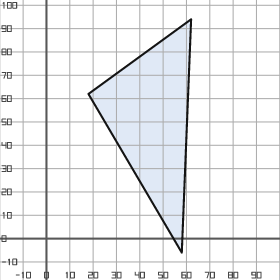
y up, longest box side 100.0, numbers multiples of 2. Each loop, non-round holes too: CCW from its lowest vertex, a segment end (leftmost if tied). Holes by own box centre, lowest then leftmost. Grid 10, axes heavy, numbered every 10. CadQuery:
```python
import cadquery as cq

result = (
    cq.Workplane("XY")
    .moveTo(58.0, -6.0)
    .lineTo(62.0, 94.0)
    .lineTo(18.0, 62.0)
    .close()
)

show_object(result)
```